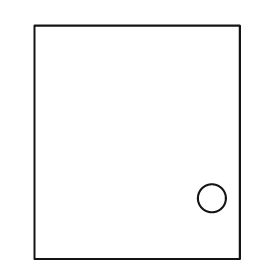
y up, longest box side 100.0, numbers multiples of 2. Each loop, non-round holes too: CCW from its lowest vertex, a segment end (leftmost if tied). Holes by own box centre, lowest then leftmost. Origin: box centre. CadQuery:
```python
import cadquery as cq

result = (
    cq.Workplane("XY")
    .moveTo(-44.0, -50.0)
    .lineTo(44.0, -50.0)
    .lineTo(44.0, 50.0)
    .lineTo(-44.0, 50.0)
    .close()
    .moveTo(32.0, -24.0)
    .circle(6.0)
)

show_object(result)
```